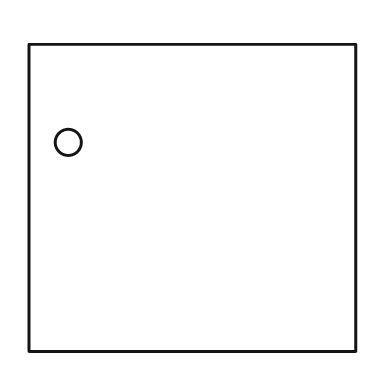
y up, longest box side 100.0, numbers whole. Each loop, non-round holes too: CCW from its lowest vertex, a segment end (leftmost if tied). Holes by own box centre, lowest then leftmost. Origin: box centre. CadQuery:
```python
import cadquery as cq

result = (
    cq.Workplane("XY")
    .moveTo(-50.0, -47.0)
    .lineTo(50.0, -47.0)
    .lineTo(50.0, 47.0)
    .lineTo(-50.0, 47.0)
    .close()
    .moveTo(-38.0, 17.0)
    .circle(4.0)
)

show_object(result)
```